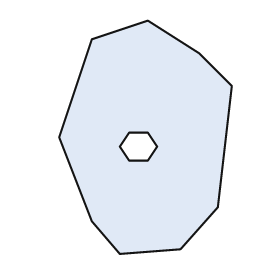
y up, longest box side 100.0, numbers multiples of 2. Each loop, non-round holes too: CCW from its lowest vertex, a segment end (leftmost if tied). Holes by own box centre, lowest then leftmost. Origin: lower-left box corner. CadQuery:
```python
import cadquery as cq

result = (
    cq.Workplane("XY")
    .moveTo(26.0, 0.0)
    .lineTo(52.0, 2.0)
    .lineTo(68.0, 20.0)
    .lineTo(74.0, 72.0)
    .lineTo(60.0, 86.0)
    .lineTo(38.0, 100.0)
    .lineTo(14.0, 92.0)
    .lineTo(0.0, 50.0)
    .lineTo(14.0, 14.0)
    .close()
    .moveTo(30.0, 40.0)
    .lineTo(38.0, 40.0)
    .lineTo(42.0, 46.0)
    .lineTo(38.0, 52.0)
    .lineTo(30.0, 52.0)
    .lineTo(26.0, 46.0)
    .close()
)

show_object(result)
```